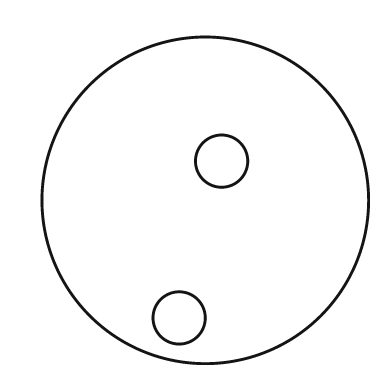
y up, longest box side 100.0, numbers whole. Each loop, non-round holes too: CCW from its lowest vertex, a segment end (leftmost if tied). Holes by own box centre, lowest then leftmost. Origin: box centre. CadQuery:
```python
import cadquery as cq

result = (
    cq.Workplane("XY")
    .moveTo(0.0, 0.0)
    .circle(50.0)
    .moveTo(-8.0, -36.0)
    .circle(8.0)
    .moveTo(5.0, 12.0)
    .circle(8.0)
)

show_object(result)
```